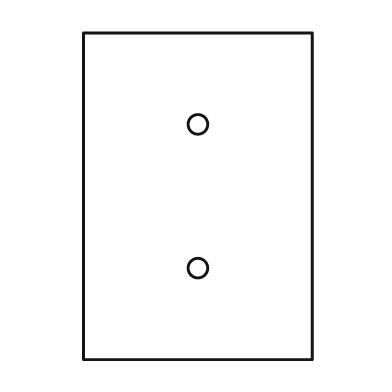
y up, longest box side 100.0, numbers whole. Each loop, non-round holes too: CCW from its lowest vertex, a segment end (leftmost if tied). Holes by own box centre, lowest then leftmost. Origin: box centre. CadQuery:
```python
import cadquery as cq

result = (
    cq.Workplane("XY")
    .moveTo(-35.0, -50.0)
    .lineTo(35.0, -50.0)
    .lineTo(35.0, 50.0)
    .lineTo(-35.0, 50.0)
    .close()
    .moveTo(0.0, -22.0)
    .circle(3.0)
    .moveTo(0.0, 22.0)
    .circle(3.0)
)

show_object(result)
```